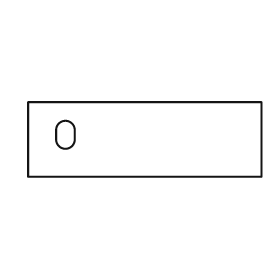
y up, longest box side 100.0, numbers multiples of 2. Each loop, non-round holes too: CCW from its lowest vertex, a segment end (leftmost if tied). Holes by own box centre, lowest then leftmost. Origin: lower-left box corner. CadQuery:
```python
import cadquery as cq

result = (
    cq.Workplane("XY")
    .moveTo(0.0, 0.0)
    .lineTo(100.0, 0.0)
    .lineTo(100.0, 32.0)
    .lineTo(0.0, 32.0)
    .close()
    .moveTo(12.0, 16.0)
    .threePointArc((16.0, 12.0), (20.0, 16.0))
    .lineTo(20.0, 20.0)
    .threePointArc((16.0, 24.0), (12.0, 20.0))
    .close()
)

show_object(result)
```